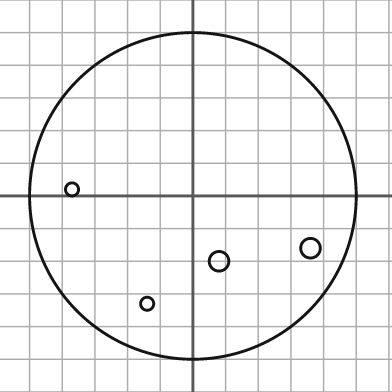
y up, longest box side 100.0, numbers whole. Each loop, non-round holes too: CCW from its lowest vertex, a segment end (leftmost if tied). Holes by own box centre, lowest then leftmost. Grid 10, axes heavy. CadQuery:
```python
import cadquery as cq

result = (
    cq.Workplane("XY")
    .moveTo(0.0, 0.0)
    .circle(50.0)
    .moveTo(-14.0, -33.0)
    .circle(2.0)
    .moveTo(8.0, -20.0)
    .circle(3.0)
    .moveTo(36.0, -16.0)
    .circle(3.0)
    .moveTo(-37.0, 2.0)
    .circle(2.0)
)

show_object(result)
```